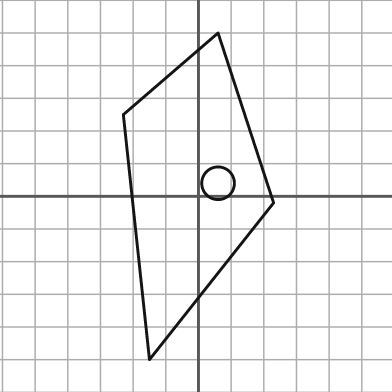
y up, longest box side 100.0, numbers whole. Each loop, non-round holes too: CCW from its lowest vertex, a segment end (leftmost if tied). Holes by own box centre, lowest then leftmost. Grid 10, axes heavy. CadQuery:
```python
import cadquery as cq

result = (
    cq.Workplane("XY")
    .moveTo(-15.0, -50.0)
    .lineTo(23.0, -2.0)
    .lineTo(6.0, 50.0)
    .lineTo(-23.0, 25.0)
    .close()
    .moveTo(6.0, 4.0)
    .circle(5.0)
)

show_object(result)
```